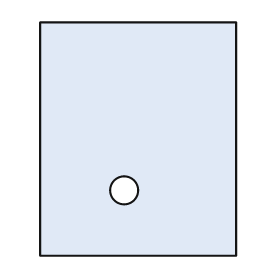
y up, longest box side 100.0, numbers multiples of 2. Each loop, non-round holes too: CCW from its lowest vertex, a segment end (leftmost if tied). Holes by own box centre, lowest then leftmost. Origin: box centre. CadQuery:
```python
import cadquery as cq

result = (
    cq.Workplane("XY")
    .moveTo(-42.0, -50.0)
    .lineTo(42.0, -50.0)
    .lineTo(42.0, 50.0)
    .lineTo(-42.0, 50.0)
    .close()
    .moveTo(-6.0, -22.0)
    .circle(6.0)
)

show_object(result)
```